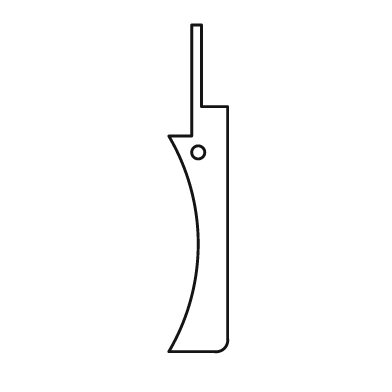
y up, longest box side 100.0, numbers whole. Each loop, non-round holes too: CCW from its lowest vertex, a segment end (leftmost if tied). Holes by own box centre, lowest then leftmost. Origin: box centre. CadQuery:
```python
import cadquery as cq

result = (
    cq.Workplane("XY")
    .moveTo(-9.0, -50.0)
    .lineTo(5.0, -50.0)
    .threePointArc((8.0, -49.0), (9.0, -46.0))
    .lineTo(9.0, 25.0)
    .lineTo(1.0, 25.0)
    .lineTo(1.0, 50.0)
    .lineTo(-2.0, 50.0)
    .lineTo(-2.0, 16.0)
    .lineTo(-9.0, 16.0)
    .threePointArc((0.0, -17.0), (-9.0, -50.0))
    .close()
    .moveTo(0.0, 11.0)
    .circle(2.0)
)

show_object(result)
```